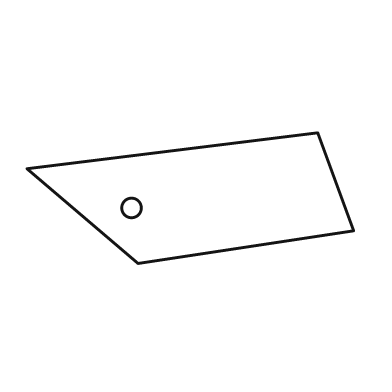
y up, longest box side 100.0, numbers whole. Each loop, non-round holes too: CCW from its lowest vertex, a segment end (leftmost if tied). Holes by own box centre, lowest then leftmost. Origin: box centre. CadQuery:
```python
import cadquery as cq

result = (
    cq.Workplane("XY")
    .moveTo(-16.0, -20.0)
    .lineTo(50.0, -10.0)
    .lineTo(39.0, 20.0)
    .lineTo(-50.0, 9.0)
    .close()
    .moveTo(-18.0, -3.0)
    .circle(3.0)
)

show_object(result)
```